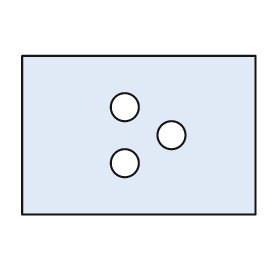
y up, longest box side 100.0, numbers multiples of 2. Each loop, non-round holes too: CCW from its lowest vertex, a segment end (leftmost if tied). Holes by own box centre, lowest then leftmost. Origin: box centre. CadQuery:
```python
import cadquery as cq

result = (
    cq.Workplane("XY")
    .moveTo(-50.0, -34.0)
    .lineTo(50.0, -34.0)
    .lineTo(50.0, 34.0)
    .lineTo(-50.0, 34.0)
    .close()
    .moveTo(-6.0, -12.0)
    .circle(6.0)
    .moveTo(14.0, 0.0)
    .circle(6.0)
    .moveTo(-6.0, 12.0)
    .circle(6.0)
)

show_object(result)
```